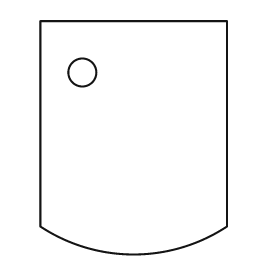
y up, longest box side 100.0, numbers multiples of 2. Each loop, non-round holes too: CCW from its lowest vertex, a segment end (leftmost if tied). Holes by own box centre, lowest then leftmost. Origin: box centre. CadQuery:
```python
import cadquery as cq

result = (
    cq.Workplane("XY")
    .moveTo(-40.0, -38.0)
    .threePointArc((0.0, -50.0), (40.0, -38.0))
    .lineTo(40.0, 50.0)
    .lineTo(-40.0, 50.0)
    .close()
    .moveTo(-22.0, 28.0)
    .circle(6.0)
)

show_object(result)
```